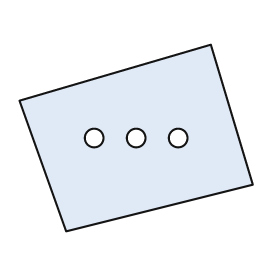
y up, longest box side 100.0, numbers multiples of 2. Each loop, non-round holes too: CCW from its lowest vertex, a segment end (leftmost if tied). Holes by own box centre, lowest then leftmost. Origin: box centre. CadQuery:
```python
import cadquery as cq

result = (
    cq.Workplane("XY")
    .moveTo(-30.0, -40.0)
    .lineTo(50.0, -20.0)
    .lineTo(32.0, 40.0)
    .lineTo(-50.0, 16.0)
    .close()
    .moveTo(-18.0, 0.0)
    .circle(4.0)
    .moveTo(0.0, 0.0)
    .circle(4.0)
    .moveTo(18.0, 0.0)
    .circle(4.0)
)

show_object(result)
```